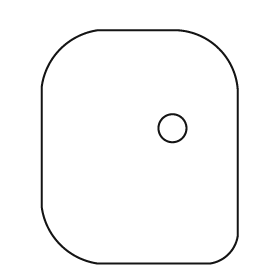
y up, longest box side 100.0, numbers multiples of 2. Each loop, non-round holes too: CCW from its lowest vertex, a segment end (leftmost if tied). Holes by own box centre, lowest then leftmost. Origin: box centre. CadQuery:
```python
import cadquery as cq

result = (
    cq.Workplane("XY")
    .moveTo(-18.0, -50.0)
    .lineTo(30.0, -50.0)
    .threePointArc((38.0, -46.0), (42.0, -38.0))
    .lineTo(42.0, 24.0)
    .threePointArc((34.0, 42.0), (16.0, 50.0))
    .lineTo(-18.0, 50.0)
    .threePointArc((-34.0, 42.0), (-42.0, 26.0))
    .lineTo(-42.0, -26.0)
    .threePointArc((-34.0, -42.0), (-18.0, -50.0))
    .close()
    .moveTo(14.0, 8.0)
    .circle(6.0)
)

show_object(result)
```